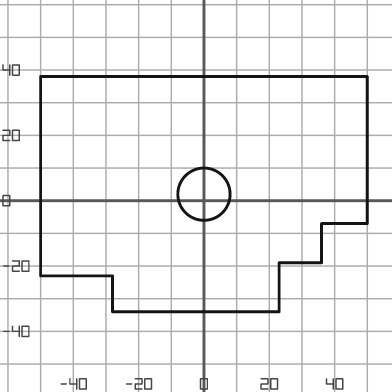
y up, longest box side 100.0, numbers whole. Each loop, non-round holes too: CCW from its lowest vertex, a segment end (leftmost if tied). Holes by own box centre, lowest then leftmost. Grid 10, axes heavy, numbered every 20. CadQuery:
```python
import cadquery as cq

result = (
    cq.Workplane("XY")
    .moveTo(-28.0, -34.0)
    .lineTo(23.0, -34.0)
    .lineTo(23.0, -19.0)
    .lineTo(36.0, -19.0)
    .lineTo(36.0, -7.0)
    .lineTo(50.0, -7.0)
    .lineTo(50.0, 38.0)
    .lineTo(-50.0, 38.0)
    .lineTo(-50.0, -23.0)
    .lineTo(-28.0, -23.0)
    .close()
    .moveTo(0.0, 2.0)
    .circle(8.0)
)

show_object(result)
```